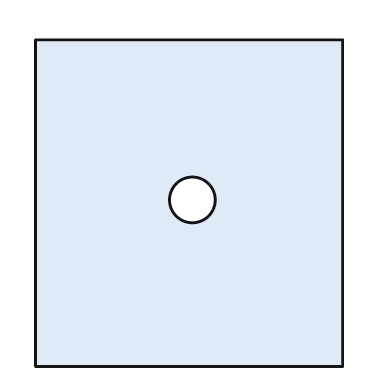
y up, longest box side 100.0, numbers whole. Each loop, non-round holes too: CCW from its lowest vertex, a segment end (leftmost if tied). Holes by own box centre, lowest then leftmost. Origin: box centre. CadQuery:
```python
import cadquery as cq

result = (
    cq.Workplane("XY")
    .moveTo(-47.0, -50.0)
    .lineTo(47.0, -50.0)
    .lineTo(47.0, 50.0)
    .lineTo(-47.0, 50.0)
    .close()
    .moveTo(1.0, 1.0)
    .circle(7.0)
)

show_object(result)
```